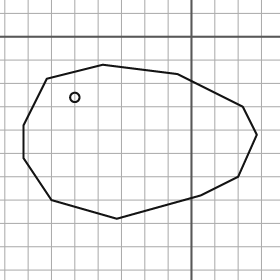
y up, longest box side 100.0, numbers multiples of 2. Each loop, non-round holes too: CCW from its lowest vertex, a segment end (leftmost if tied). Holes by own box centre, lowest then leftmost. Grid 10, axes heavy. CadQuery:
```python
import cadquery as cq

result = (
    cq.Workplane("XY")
    .moveTo(-32.0, -78.0)
    .lineTo(4.0, -68.0)
    .lineTo(20.0, -60.0)
    .lineTo(28.0, -42.0)
    .lineTo(22.0, -30.0)
    .lineTo(-6.0, -16.0)
    .lineTo(-38.0, -12.0)
    .lineTo(-62.0, -18.0)
    .lineTo(-72.0, -38.0)
    .lineTo(-72.0, -52.0)
    .lineTo(-60.0, -70.0)
    .close()
    .moveTo(-50.0, -26.0)
    .circle(2.0)
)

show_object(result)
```